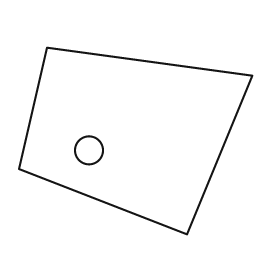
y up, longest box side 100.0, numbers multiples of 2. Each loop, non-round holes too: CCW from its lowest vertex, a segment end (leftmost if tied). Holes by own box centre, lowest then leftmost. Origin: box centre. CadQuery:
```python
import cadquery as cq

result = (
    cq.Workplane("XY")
    .moveTo(22.0, -40.0)
    .lineTo(50.0, 28.0)
    .lineTo(-38.0, 40.0)
    .lineTo(-50.0, -12.0)
    .close()
    .moveTo(-20.0, -4.0)
    .circle(6.0)
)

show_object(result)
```